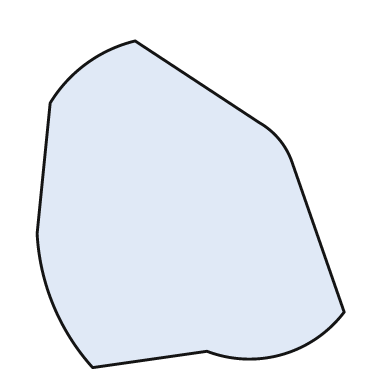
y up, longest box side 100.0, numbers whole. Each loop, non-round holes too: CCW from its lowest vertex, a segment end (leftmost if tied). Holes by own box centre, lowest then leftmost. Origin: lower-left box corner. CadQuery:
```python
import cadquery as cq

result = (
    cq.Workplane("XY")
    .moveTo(17.0, 0.0)
    .lineTo(52.0, 5.0)
    .threePointArc((75.0, 4.0), (94.0, 17.0))
    .lineTo(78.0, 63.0)
    .threePointArc((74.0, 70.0), (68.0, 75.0))
    .lineTo(30.0, 100.0)
    .threePointArc((15.0, 93.0), (4.0, 81.0))
    .lineTo(0.0, 41.0)
    .threePointArc((5.0, 19.0), (17.0, 0.0))
    .close()
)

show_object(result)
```